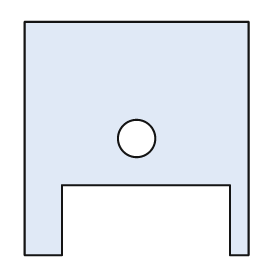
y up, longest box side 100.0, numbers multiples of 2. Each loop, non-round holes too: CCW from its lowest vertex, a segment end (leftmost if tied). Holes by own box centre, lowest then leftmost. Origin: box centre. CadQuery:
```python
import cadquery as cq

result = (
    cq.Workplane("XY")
    .moveTo(-48.0, -50.0)
    .lineTo(-32.0, -50.0)
    .lineTo(-32.0, -20.0)
    .lineTo(40.0, -20.0)
    .lineTo(40.0, -50.0)
    .lineTo(48.0, -50.0)
    .lineTo(48.0, 50.0)
    .lineTo(-48.0, 50.0)
    .close()
    .moveTo(0.0, 0.0)
    .circle(8.0)
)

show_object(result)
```